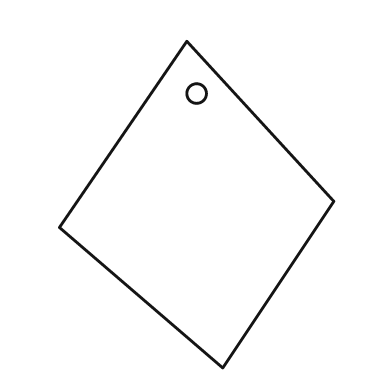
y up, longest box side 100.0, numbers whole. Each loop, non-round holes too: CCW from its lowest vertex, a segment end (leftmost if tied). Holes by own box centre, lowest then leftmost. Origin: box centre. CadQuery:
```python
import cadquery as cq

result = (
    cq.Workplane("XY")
    .moveTo(8.0, -50.0)
    .lineTo(42.0, 1.0)
    .lineTo(-3.0, 50.0)
    .lineTo(-42.0, -7.0)
    .close()
    .moveTo(0.0, 34.0)
    .circle(3.0)
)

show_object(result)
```